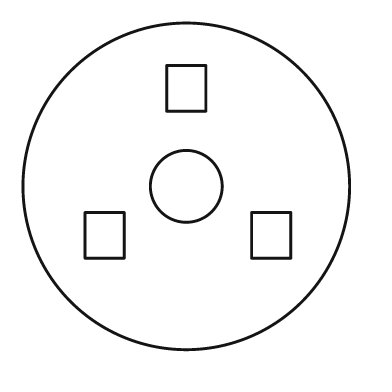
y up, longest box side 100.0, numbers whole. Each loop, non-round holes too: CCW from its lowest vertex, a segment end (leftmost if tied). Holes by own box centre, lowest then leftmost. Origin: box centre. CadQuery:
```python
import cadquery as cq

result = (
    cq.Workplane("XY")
    .moveTo(0.0, 0.0)
    .circle(50.0)
    .moveTo(-31.0, -22.0)
    .lineTo(-19.0, -22.0)
    .lineTo(-19.0, -8.0)
    .lineTo(-31.0, -8.0)
    .close()
    .moveTo(20.0, -22.0)
    .lineTo(32.0, -22.0)
    .lineTo(32.0, -8.0)
    .lineTo(20.0, -8.0)
    .close()
    .moveTo(0.0, 0.0)
    .circle(11.0)
    .moveTo(-6.0, 23.0)
    .lineTo(6.0, 23.0)
    .lineTo(6.0, 37.0)
    .lineTo(-6.0, 37.0)
    .close()
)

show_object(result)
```